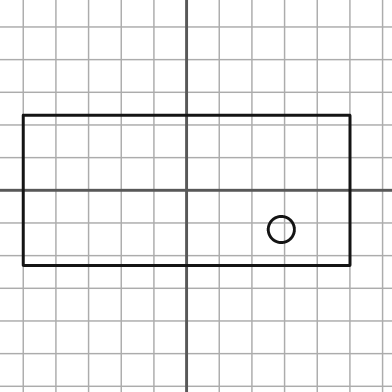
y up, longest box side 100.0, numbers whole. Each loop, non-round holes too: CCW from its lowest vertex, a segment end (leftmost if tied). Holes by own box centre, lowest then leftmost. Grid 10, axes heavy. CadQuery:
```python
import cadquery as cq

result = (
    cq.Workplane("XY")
    .moveTo(-50.0, -23.0)
    .lineTo(50.0, -23.0)
    .lineTo(50.0, 23.0)
    .lineTo(-50.0, 23.0)
    .close()
    .moveTo(29.0, -12.0)
    .circle(4.0)
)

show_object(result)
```